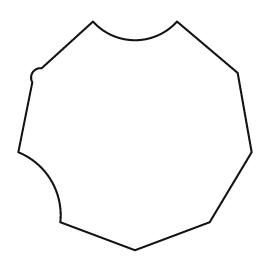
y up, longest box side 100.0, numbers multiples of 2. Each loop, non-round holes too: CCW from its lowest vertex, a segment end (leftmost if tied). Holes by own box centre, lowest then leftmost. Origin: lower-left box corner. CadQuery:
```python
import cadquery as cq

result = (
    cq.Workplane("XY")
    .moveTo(50.0, 0.0)
    .lineTo(82.0, 12.0)
    .lineTo(100.0, 42.0)
    .lineTo(94.0, 76.0)
    .lineTo(68.0, 98.0)
    .threePointArc((50.0, 90.0), (32.0, 98.0))
    .lineTo(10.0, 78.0)
    .threePointArc((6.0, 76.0), (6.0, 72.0))
    .lineTo(0.0, 42.0)
    .threePointArc((14.0, 30.0), (18.0, 12.0))
    .close()
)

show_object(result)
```